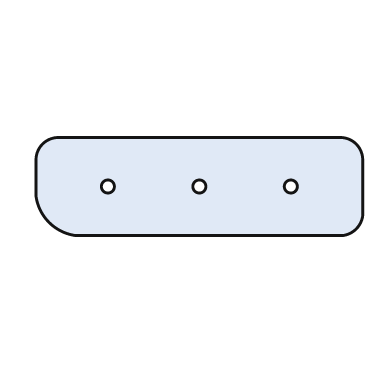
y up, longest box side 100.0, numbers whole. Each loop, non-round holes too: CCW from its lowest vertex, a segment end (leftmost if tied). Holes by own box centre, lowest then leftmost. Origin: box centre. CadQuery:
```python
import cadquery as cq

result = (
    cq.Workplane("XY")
    .moveTo(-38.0, -15.0)
    .lineTo(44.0, -15.0)
    .threePointArc((48.0, -13.0), (50.0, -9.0))
    .lineTo(50.0, 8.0)
    .threePointArc((48.0, 13.0), (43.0, 15.0))
    .lineTo(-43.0, 15.0)
    .threePointArc((-48.0, 13.0), (-50.0, 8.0))
    .lineTo(-50.0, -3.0)
    .threePointArc((-46.0, -11.0), (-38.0, -15.0))
    .close()
    .moveTo(-28.0, 0.0)
    .circle(2.0)
    .moveTo(0.0, 0.0)
    .circle(2.0)
    .moveTo(28.0, 0.0)
    .circle(2.0)
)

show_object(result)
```